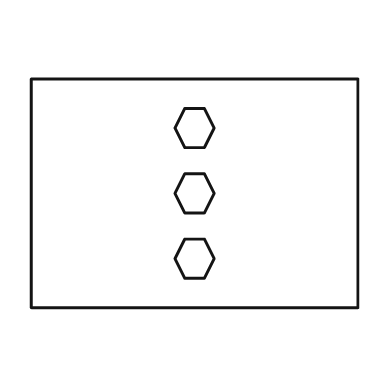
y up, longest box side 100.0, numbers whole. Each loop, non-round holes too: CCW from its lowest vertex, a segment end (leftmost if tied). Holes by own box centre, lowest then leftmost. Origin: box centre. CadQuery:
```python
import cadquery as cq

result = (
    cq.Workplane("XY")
    .moveTo(-50.0, -35.0)
    .lineTo(50.0, -35.0)
    .lineTo(50.0, 35.0)
    .lineTo(-50.0, 35.0)
    .close()
    .moveTo(-3.0, -26.0)
    .lineTo(3.0, -26.0)
    .lineTo(6.0, -20.0)
    .lineTo(3.0, -14.0)
    .lineTo(-3.0, -14.0)
    .lineTo(-6.0, -20.0)
    .close()
    .moveTo(-3.0, -6.0)
    .lineTo(3.0, -6.0)
    .lineTo(6.0, 0.0)
    .lineTo(3.0, 6.0)
    .lineTo(-3.0, 6.0)
    .lineTo(-6.0, 0.0)
    .close()
    .moveTo(-3.0, 14.0)
    .lineTo(3.0, 14.0)
    .lineTo(6.0, 20.0)
    .lineTo(3.0, 26.0)
    .lineTo(-3.0, 26.0)
    .lineTo(-6.0, 20.0)
    .close()
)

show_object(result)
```